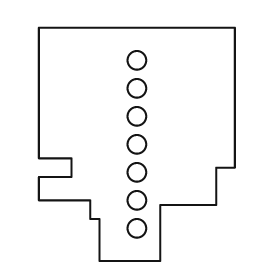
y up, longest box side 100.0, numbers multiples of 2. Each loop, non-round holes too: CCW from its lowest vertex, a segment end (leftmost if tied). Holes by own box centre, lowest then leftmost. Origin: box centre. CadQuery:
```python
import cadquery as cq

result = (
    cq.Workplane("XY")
    .moveTo(-16.0, -50.0)
    .lineTo(10.0, -50.0)
    .lineTo(10.0, -26.0)
    .lineTo(34.0, -26.0)
    .lineTo(34.0, -10.0)
    .lineTo(42.0, -10.0)
    .lineTo(42.0, 50.0)
    .lineTo(-42.0, 50.0)
    .lineTo(-42.0, -6.0)
    .lineTo(-28.0, -6.0)
    .lineTo(-28.0, -14.0)
    .lineTo(-42.0, -14.0)
    .lineTo(-42.0, -24.0)
    .lineTo(-20.0, -24.0)
    .lineTo(-20.0, -32.0)
    .lineTo(-16.0, -32.0)
    .close()
    .moveTo(0.0, -36.0)
    .circle(4.0)
    .moveTo(0.0, -24.0)
    .circle(4.0)
    .moveTo(0.0, -12.0)
    .circle(4.0)
    .moveTo(0.0, 0.0)
    .circle(4.0)
    .moveTo(0.0, 12.0)
    .circle(4.0)
    .moveTo(0.0, 24.0)
    .circle(4.0)
    .moveTo(0.0, 36.0)
    .circle(4.0)
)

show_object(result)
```